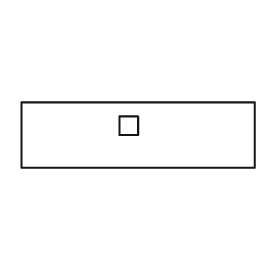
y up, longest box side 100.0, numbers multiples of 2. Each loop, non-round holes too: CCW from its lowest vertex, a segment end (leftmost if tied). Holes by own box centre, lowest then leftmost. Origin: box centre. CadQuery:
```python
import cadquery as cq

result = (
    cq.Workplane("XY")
    .moveTo(-50.0, -14.0)
    .lineTo(50.0, -14.0)
    .lineTo(50.0, 14.0)
    .lineTo(-50.0, 14.0)
    .close()
    .moveTo(-8.0, 0.0)
    .lineTo(0.0, 0.0)
    .lineTo(0.0, 8.0)
    .lineTo(-8.0, 8.0)
    .close()
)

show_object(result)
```